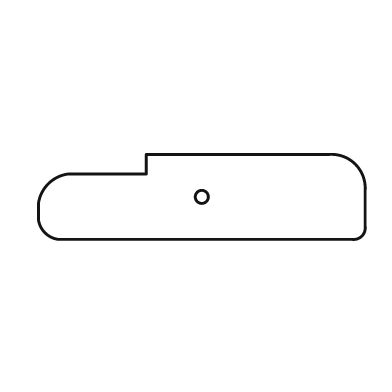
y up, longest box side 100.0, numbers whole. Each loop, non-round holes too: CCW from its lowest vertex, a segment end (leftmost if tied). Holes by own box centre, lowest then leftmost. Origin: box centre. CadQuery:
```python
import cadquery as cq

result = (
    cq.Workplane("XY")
    .moveTo(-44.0, -13.0)
    .lineTo(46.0, -13.0)
    .threePointArc((49.0, -12.0), (50.0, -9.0))
    .lineTo(50.0, 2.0)
    .threePointArc((47.0, 10.0), (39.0, 13.0))
    .lineTo(-17.0, 13.0)
    .lineTo(-17.0, 7.0)
    .lineTo(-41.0, 7.0)
    .threePointArc((-47.0, 4.0), (-50.0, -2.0))
    .lineTo(-50.0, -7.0)
    .threePointArc((-48.0, -11.0), (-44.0, -13.0))
    .close()
    .moveTo(0.0, 0.0)
    .circle(2.0)
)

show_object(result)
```